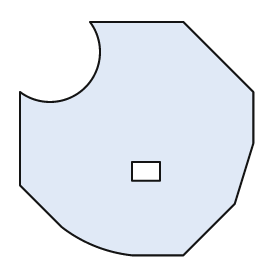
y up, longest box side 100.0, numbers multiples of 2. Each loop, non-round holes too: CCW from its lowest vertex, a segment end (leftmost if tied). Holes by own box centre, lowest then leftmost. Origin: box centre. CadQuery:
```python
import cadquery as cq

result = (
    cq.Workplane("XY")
    .moveTo(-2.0, -50.0)
    .lineTo(20.0, -50.0)
    .lineTo(42.0, -28.0)
    .lineTo(50.0, -2.0)
    .lineTo(50.0, 20.0)
    .lineTo(20.0, 50.0)
    .lineTo(-20.0, 50.0)
    .threePointArc((-22.0, 22.0), (-50.0, 20.0))
    .lineTo(-50.0, -20.0)
    .lineTo(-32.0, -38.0)
    .threePointArc((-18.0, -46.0), (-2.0, -50.0))
    .close()
    .moveTo(-2.0, -18.0)
    .lineTo(10.0, -18.0)
    .lineTo(10.0, -10.0)
    .lineTo(-2.0, -10.0)
    .close()
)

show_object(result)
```